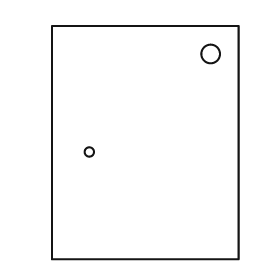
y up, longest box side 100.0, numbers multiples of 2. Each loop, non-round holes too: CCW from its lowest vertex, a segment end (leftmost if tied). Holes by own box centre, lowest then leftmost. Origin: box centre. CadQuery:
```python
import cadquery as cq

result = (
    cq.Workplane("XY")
    .moveTo(-40.0, -50.0)
    .lineTo(40.0, -50.0)
    .lineTo(40.0, 50.0)
    .lineTo(-40.0, 50.0)
    .close()
    .moveTo(-24.0, -4.0)
    .circle(2.0)
    .moveTo(28.0, 38.0)
    .circle(4.0)
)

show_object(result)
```